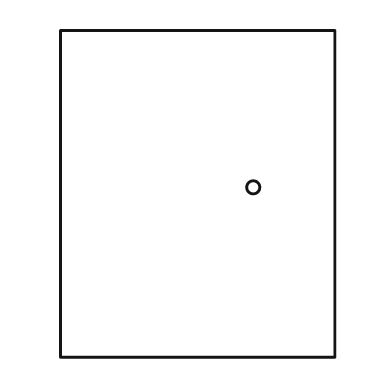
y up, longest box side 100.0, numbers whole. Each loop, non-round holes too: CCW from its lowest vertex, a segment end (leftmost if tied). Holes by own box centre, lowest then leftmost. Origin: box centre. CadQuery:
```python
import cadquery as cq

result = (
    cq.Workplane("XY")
    .moveTo(-42.0, -50.0)
    .lineTo(42.0, -50.0)
    .lineTo(42.0, 50.0)
    .lineTo(-42.0, 50.0)
    .close()
    .moveTo(17.0, 2.0)
    .circle(2.0)
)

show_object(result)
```